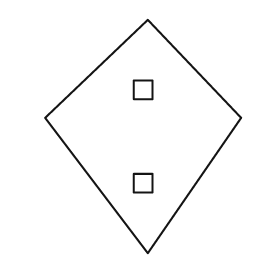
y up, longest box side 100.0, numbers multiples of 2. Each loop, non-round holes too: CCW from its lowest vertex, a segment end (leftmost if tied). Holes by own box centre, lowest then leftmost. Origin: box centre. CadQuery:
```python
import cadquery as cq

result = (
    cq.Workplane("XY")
    .moveTo(2.0, -50.0)
    .lineTo(42.0, 8.0)
    .lineTo(2.0, 50.0)
    .lineTo(-42.0, 8.0)
    .close()
    .moveTo(-4.0, -24.0)
    .lineTo(4.0, -24.0)
    .lineTo(4.0, -16.0)
    .lineTo(-4.0, -16.0)
    .close()
    .moveTo(-4.0, 16.0)
    .lineTo(4.0, 16.0)
    .lineTo(4.0, 24.0)
    .lineTo(-4.0, 24.0)
    .close()
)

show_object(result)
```